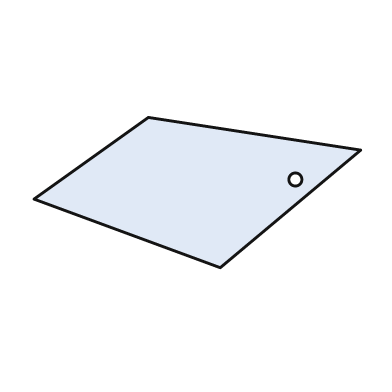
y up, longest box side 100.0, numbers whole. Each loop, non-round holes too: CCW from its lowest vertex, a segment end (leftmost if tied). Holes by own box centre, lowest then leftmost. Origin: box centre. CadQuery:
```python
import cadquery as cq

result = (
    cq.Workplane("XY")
    .moveTo(7.0, -23.0)
    .lineTo(50.0, 13.0)
    .lineTo(-15.0, 23.0)
    .lineTo(-50.0, -2.0)
    .close()
    .moveTo(30.0, 4.0)
    .circle(2.0)
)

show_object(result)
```